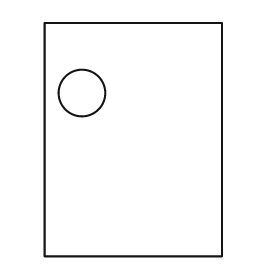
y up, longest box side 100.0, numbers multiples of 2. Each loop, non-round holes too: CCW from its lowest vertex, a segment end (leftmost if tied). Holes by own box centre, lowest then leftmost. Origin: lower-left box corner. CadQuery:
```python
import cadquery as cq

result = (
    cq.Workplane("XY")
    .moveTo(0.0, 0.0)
    .lineTo(76.0, 0.0)
    .lineTo(76.0, 100.0)
    .lineTo(0.0, 100.0)
    .close()
    .moveTo(16.0, 70.0)
    .circle(10.0)
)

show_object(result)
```